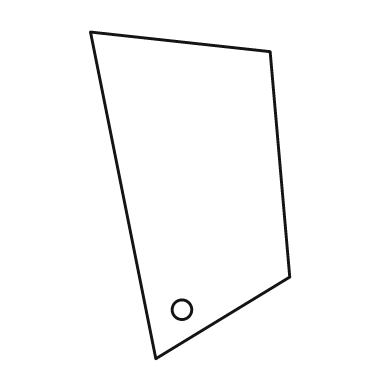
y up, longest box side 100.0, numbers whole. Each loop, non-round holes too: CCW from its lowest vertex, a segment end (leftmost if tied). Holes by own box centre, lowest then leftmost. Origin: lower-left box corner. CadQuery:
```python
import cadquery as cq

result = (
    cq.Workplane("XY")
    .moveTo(20.0, 0.0)
    .lineTo(61.0, 25.0)
    .lineTo(55.0, 94.0)
    .lineTo(0.0, 100.0)
    .close()
    .moveTo(28.0, 15.0)
    .circle(3.0)
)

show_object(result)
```